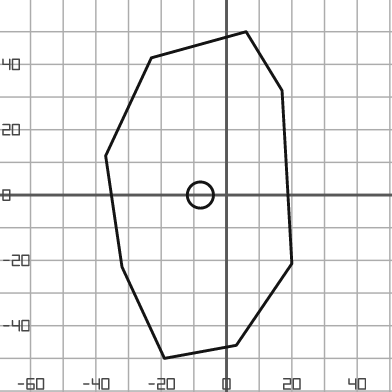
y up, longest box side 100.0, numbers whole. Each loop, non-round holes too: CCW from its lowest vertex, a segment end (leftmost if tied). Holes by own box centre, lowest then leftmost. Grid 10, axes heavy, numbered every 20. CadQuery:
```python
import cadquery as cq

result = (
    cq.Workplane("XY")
    .moveTo(-19.0, -50.0)
    .lineTo(3.0, -46.0)
    .lineTo(20.0, -21.0)
    .lineTo(17.0, 32.0)
    .lineTo(6.0, 50.0)
    .lineTo(-23.0, 42.0)
    .lineTo(-37.0, 12.0)
    .lineTo(-32.0, -22.0)
    .close()
    .moveTo(-8.0, 0.0)
    .circle(4.0)
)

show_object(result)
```